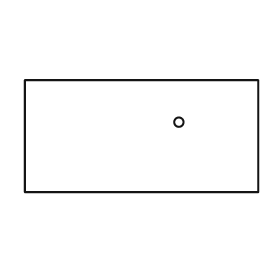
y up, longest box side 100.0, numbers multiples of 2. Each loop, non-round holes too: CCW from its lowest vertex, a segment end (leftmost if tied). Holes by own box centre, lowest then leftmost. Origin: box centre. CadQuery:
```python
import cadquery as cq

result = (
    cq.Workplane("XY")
    .moveTo(-50.0, -24.0)
    .lineTo(50.0, -24.0)
    .lineTo(50.0, 24.0)
    .lineTo(-50.0, 24.0)
    .close()
    .moveTo(16.0, 6.0)
    .circle(2.0)
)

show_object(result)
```